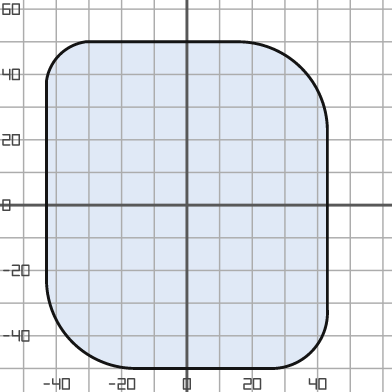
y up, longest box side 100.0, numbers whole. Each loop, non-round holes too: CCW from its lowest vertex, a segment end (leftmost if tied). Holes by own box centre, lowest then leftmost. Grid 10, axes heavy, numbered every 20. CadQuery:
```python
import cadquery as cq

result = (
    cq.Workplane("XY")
    .moveTo(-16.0, -50.0)
    .lineTo(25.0, -50.0)
    .threePointArc((38.0, -45.0), (43.0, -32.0))
    .lineTo(43.0, 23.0)
    .threePointArc((35.0, 42.0), (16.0, 50.0))
    .lineTo(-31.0, 50.0)
    .threePointArc((-39.0, 46.0), (-43.0, 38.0))
    .lineTo(-43.0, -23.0)
    .threePointArc((-35.0, -42.0), (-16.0, -50.0))
    .close()
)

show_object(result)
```